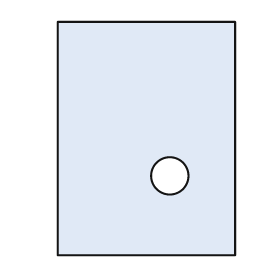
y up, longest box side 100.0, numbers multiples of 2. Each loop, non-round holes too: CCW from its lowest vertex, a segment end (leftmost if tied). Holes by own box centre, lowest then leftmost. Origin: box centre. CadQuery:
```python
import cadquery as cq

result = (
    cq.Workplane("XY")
    .moveTo(-38.0, -50.0)
    .lineTo(38.0, -50.0)
    .lineTo(38.0, 50.0)
    .lineTo(-38.0, 50.0)
    .close()
    .moveTo(10.0, -16.0)
    .circle(8.0)
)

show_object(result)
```